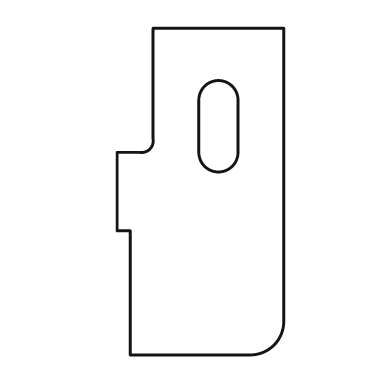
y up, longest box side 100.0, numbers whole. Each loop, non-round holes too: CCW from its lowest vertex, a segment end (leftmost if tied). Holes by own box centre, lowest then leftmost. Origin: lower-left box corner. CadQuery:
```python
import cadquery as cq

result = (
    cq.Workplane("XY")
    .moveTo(4.0, 0.0)
    .lineTo(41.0, 0.0)
    .threePointArc((48.0, 3.0), (51.0, 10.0))
    .lineTo(51.0, 100.0)
    .lineTo(11.0, 100.0)
    .lineTo(11.0, 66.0)
    .threePointArc((10.0, 63.0), (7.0, 62.0))
    .lineTo(0.0, 62.0)
    .lineTo(0.0, 38.0)
    .lineTo(4.0, 38.0)
    .close()
    .moveTo(25.0, 62.0)
    .threePointArc((31.0, 56.0), (37.0, 62.0))
    .lineTo(37.0, 78.0)
    .threePointArc((31.0, 84.0), (25.0, 78.0))
    .close()
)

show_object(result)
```